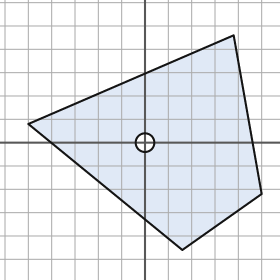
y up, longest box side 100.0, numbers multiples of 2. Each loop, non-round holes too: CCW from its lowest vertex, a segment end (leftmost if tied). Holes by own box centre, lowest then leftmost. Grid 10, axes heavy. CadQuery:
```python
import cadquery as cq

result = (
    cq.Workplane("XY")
    .moveTo(16.0, -46.0)
    .lineTo(50.0, -22.0)
    .lineTo(38.0, 46.0)
    .lineTo(-50.0, 8.0)
    .close()
    .moveTo(0.0, 0.0)
    .circle(4.0)
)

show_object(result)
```